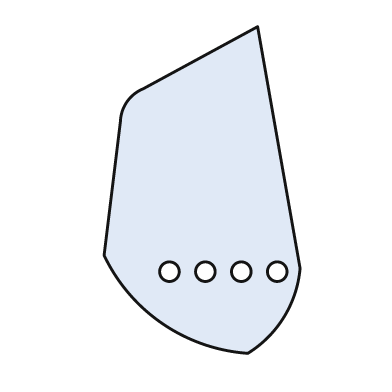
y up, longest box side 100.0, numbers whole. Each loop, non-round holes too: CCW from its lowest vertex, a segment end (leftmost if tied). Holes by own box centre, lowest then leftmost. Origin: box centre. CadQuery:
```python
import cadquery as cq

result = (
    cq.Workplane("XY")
    .moveTo(14.0, -50.0)
    .threePointArc((25.0, -39.0), (30.0, -24.0))
    .lineTo(17.0, 50.0)
    .lineTo(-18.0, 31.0)
    .threePointArc((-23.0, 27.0), (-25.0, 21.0))
    .lineTo(-30.0, -20.0)
    .threePointArc((-12.0, -41.0), (14.0, -50.0))
    .close()
    .moveTo(-10.0, -25.0)
    .circle(3.0)
    .moveTo(1.0, -25.0)
    .circle(3.0)
    .moveTo(12.0, -25.0)
    .circle(3.0)
    .moveTo(23.0, -25.0)
    .circle(3.0)
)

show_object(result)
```